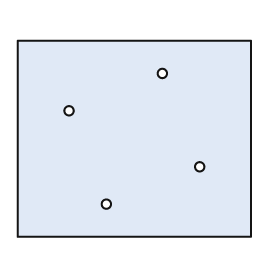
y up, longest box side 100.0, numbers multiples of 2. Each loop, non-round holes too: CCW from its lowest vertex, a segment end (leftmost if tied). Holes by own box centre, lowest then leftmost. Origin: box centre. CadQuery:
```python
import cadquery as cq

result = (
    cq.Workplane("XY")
    .moveTo(-50.0, -42.0)
    .lineTo(50.0, -42.0)
    .lineTo(50.0, 42.0)
    .lineTo(-50.0, 42.0)
    .close()
    .moveTo(-12.0, -28.0)
    .circle(2.0)
    .moveTo(28.0, -12.0)
    .circle(2.0)
    .moveTo(-28.0, 12.0)
    .circle(2.0)
    .moveTo(12.0, 28.0)
    .circle(2.0)
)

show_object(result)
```